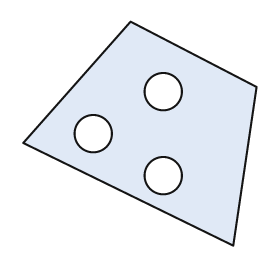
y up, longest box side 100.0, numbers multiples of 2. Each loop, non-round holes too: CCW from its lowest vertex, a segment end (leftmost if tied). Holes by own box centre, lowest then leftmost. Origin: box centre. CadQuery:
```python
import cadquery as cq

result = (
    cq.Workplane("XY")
    .moveTo(40.0, -48.0)
    .lineTo(50.0, 20.0)
    .lineTo(-4.0, 48.0)
    .lineTo(-50.0, -4.0)
    .close()
    .moveTo(10.0, -18.0)
    .circle(8.0)
    .moveTo(-20.0, 0.0)
    .circle(8.0)
    .moveTo(10.0, 18.0)
    .circle(8.0)
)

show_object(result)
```